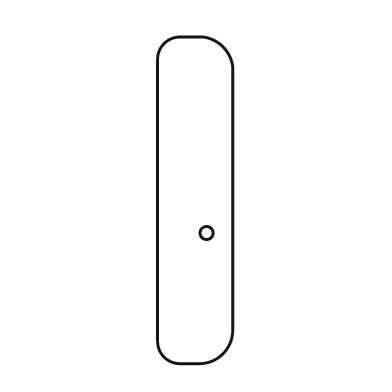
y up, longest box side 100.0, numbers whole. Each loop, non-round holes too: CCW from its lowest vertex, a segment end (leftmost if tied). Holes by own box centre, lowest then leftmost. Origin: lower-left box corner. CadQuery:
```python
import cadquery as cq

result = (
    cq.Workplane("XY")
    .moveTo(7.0, 0.0)
    .lineTo(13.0, 0.0)
    .threePointArc((20.0, 3.0), (23.0, 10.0))
    .lineTo(23.0, 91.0)
    .threePointArc((20.0, 97.0), (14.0, 100.0))
    .lineTo(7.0, 100.0)
    .threePointArc((2.0, 98.0), (0.0, 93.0))
    .lineTo(0.0, 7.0)
    .threePointArc((2.0, 2.0), (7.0, 0.0))
    .close()
    .moveTo(15.0, 40.0)
    .circle(2.0)
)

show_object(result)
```